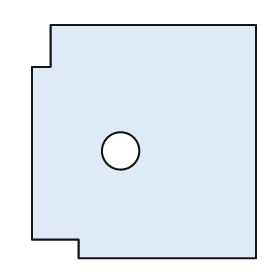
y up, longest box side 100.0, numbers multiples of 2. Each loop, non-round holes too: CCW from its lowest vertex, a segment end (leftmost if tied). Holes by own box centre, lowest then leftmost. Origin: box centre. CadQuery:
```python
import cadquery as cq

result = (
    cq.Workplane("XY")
    .moveTo(-28.0, -50.0)
    .lineTo(48.0, -50.0)
    .lineTo(48.0, 50.0)
    .lineTo(-40.0, 50.0)
    .lineTo(-40.0, 32.0)
    .lineTo(-48.0, 32.0)
    .lineTo(-48.0, -42.0)
    .lineTo(-28.0, -42.0)
    .close()
    .moveTo(-10.0, -4.0)
    .circle(8.0)
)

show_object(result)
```